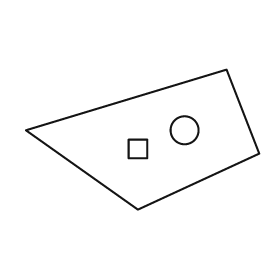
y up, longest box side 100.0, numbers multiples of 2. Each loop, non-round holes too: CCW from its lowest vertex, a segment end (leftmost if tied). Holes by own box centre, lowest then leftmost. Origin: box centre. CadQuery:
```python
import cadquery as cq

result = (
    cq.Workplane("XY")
    .moveTo(-2.0, -30.0)
    .lineTo(50.0, -6.0)
    .lineTo(36.0, 30.0)
    .lineTo(-50.0, 4.0)
    .close()
    .moveTo(-6.0, -8.0)
    .lineTo(2.0, -8.0)
    .lineTo(2.0, 0.0)
    .lineTo(-6.0, 0.0)
    .close()
    .moveTo(18.0, 4.0)
    .circle(6.0)
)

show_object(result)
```